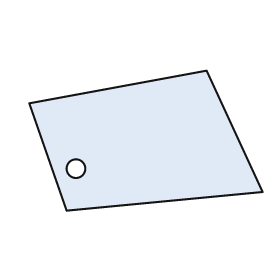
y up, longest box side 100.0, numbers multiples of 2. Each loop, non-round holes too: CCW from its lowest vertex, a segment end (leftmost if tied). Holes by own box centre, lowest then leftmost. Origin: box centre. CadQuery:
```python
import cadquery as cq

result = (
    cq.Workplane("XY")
    .moveTo(-34.0, -30.0)
    .lineTo(50.0, -22.0)
    .lineTo(26.0, 30.0)
    .lineTo(-50.0, 16.0)
    .close()
    .moveTo(-30.0, -12.0)
    .circle(4.0)
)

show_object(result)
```